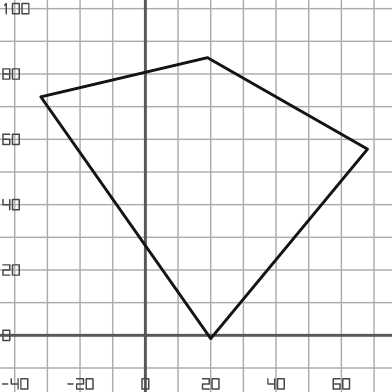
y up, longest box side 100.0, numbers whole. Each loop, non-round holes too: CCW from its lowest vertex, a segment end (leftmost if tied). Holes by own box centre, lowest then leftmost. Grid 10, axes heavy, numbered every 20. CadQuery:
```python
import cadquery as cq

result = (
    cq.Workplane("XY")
    .moveTo(20.0, -1.0)
    .lineTo(68.0, 57.0)
    .lineTo(19.0, 85.0)
    .lineTo(-32.0, 73.0)
    .close()
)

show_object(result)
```